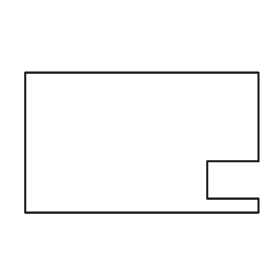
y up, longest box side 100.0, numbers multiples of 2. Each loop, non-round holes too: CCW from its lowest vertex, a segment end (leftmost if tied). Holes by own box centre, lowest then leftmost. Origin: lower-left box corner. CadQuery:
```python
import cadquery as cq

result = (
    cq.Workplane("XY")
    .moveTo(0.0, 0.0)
    .lineTo(100.0, 0.0)
    .lineTo(100.0, 6.0)
    .lineTo(78.0, 6.0)
    .lineTo(78.0, 22.0)
    .lineTo(100.0, 22.0)
    .lineTo(100.0, 60.0)
    .lineTo(0.0, 60.0)
    .close()
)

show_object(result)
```